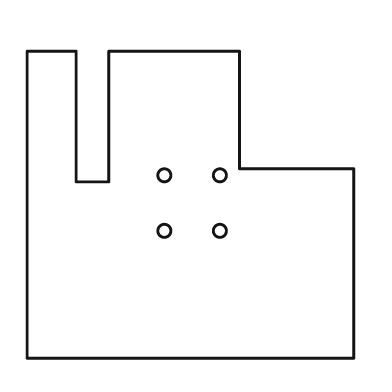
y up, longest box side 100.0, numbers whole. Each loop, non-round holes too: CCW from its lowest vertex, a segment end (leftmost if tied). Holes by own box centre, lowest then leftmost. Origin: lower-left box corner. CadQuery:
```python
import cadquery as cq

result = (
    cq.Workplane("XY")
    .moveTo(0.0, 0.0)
    .lineTo(100.0, 0.0)
    .lineTo(100.0, 58.0)
    .lineTo(65.0, 58.0)
    .lineTo(65.0, 94.0)
    .lineTo(25.0, 94.0)
    .lineTo(25.0, 54.0)
    .lineTo(15.0, 54.0)
    .lineTo(15.0, 94.0)
    .lineTo(0.0, 94.0)
    .close()
    .moveTo(42.0, 39.0)
    .circle(2.0)
    .moveTo(59.0, 39.0)
    .circle(2.0)
    .moveTo(42.0, 56.0)
    .circle(2.0)
    .moveTo(59.0, 56.0)
    .circle(2.0)
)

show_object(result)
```